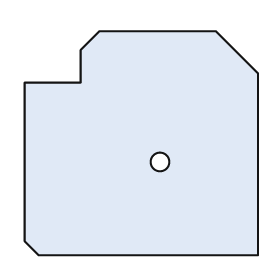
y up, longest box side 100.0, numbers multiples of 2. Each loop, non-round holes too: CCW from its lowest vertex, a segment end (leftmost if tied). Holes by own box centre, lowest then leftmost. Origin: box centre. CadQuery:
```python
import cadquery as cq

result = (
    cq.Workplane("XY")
    .moveTo(-44.0, -48.0)
    .lineTo(50.0, -48.0)
    .lineTo(50.0, 30.0)
    .lineTo(32.0, 48.0)
    .lineTo(-18.0, 48.0)
    .lineTo(-26.0, 40.0)
    .lineTo(-26.0, 26.0)
    .lineTo(-50.0, 26.0)
    .lineTo(-50.0, -42.0)
    .close()
    .moveTo(8.0, -8.0)
    .circle(4.0)
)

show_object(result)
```